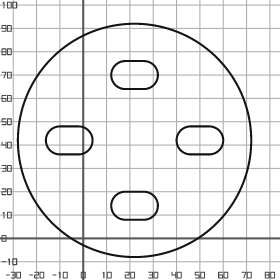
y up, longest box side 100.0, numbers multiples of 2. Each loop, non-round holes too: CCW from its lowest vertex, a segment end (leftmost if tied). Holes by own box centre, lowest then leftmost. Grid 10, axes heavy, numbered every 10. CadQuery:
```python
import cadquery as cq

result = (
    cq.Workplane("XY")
    .moveTo(22.0, 42.0)
    .circle(50.0)
    .moveTo(18.0, 8.0)
    .lineTo(26.0, 8.0)
    .threePointArc((32.0, 14.0), (26.0, 20.0))
    .lineTo(18.0, 20.0)
    .threePointArc((12.0, 14.0), (18.0, 8.0))
    .close()
    .moveTo(-10.0, 36.0)
    .lineTo(-2.0, 36.0)
    .threePointArc((4.0, 42.0), (-2.0, 48.0))
    .lineTo(-10.0, 48.0)
    .threePointArc((-16.0, 42.0), (-10.0, 36.0))
    .close()
    .moveTo(46.0, 36.0)
    .lineTo(54.0, 36.0)
    .threePointArc((60.0, 42.0), (54.0, 48.0))
    .lineTo(46.0, 48.0)
    .threePointArc((40.0, 42.0), (46.0, 36.0))
    .close()
    .moveTo(18.0, 64.0)
    .lineTo(26.0, 64.0)
    .threePointArc((32.0, 70.0), (26.0, 76.0))
    .lineTo(18.0, 76.0)
    .threePointArc((12.0, 70.0), (18.0, 64.0))
    .close()
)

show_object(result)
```